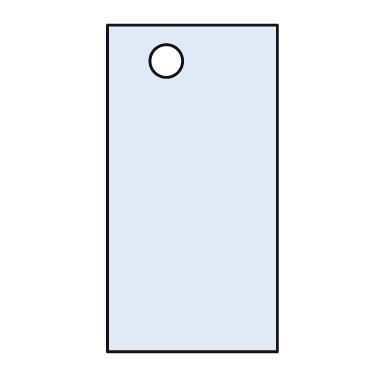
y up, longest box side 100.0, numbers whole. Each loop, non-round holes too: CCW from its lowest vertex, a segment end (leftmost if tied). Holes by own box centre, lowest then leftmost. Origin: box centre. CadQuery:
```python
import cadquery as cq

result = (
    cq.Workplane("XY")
    .moveTo(-26.0, -50.0)
    .lineTo(26.0, -50.0)
    .lineTo(26.0, 50.0)
    .lineTo(-26.0, 50.0)
    .close()
    .moveTo(-8.0, 39.0)
    .circle(5.0)
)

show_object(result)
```